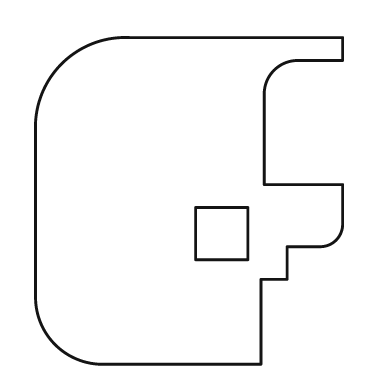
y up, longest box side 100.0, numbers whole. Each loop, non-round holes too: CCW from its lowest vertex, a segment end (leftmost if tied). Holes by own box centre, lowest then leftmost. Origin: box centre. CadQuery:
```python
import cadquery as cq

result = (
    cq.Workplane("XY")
    .moveTo(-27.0, -50.0)
    .lineTo(22.0, -50.0)
    .lineTo(22.0, -24.0)
    .lineTo(30.0, -24.0)
    .lineTo(30.0, -14.0)
    .lineTo(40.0, -14.0)
    .threePointArc((45.0, -12.0), (47.0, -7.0))
    .lineTo(47.0, 5.0)
    .lineTo(23.0, 5.0)
    .lineTo(23.0, 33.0)
    .threePointArc((26.0, 40.0), (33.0, 43.0))
    .lineTo(47.0, 43.0)
    .lineTo(47.0, 50.0)
    .lineTo(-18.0, 50.0)
    .threePointArc((-39.0, 42.0), (-47.0, 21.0))
    .lineTo(-47.0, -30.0)
    .threePointArc((-41.0, -44.0), (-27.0, -50.0))
    .close()
    .moveTo(2.0, -18.0)
    .lineTo(18.0, -18.0)
    .lineTo(18.0, -2.0)
    .lineTo(2.0, -2.0)
    .close()
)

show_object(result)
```